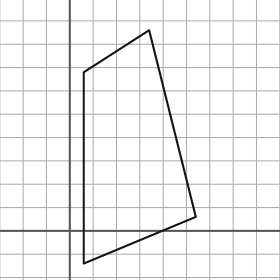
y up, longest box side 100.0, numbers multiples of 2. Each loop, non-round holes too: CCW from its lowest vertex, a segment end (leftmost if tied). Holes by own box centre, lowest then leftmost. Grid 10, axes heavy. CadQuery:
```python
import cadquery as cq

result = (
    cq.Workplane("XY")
    .moveTo(6.0, -14.0)
    .lineTo(54.0, 6.0)
    .lineTo(34.0, 86.0)
    .lineTo(6.0, 68.0)
    .close()
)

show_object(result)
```